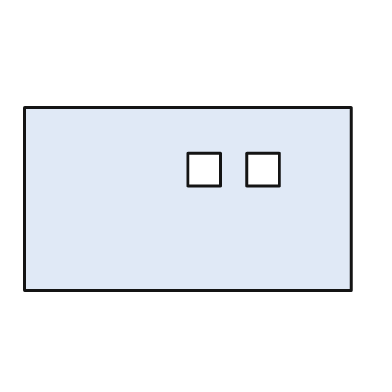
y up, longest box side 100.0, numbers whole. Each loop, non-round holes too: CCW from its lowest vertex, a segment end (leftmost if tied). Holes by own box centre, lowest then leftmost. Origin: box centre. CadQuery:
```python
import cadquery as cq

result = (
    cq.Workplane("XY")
    .moveTo(-50.0, -28.0)
    .lineTo(50.0, -28.0)
    .lineTo(50.0, 28.0)
    .lineTo(-50.0, 28.0)
    .close()
    .moveTo(0.0, 4.0)
    .lineTo(10.0, 4.0)
    .lineTo(10.0, 14.0)
    .lineTo(0.0, 14.0)
    .close()
    .moveTo(18.0, 4.0)
    .lineTo(28.0, 4.0)
    .lineTo(28.0, 14.0)
    .lineTo(18.0, 14.0)
    .close()
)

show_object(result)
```